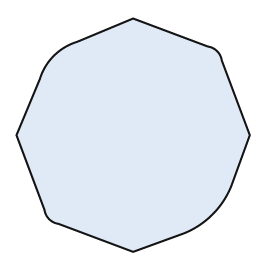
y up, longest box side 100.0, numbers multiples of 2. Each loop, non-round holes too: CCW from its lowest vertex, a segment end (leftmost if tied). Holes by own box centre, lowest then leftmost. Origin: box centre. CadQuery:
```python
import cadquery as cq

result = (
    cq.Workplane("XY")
    .moveTo(0.0, -50.0)
    .lineTo(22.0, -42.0)
    .threePointArc((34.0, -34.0), (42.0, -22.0))
    .lineTo(50.0, 0.0)
    .lineTo(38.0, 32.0)
    .threePointArc((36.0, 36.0), (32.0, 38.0))
    .lineTo(0.0, 50.0)
    .lineTo(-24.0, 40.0)
    .threePointArc((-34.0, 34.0), (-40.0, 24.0))
    .lineTo(-50.0, 0.0)
    .lineTo(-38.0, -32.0)
    .threePointArc((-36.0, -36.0), (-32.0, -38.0))
    .close()
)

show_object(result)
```